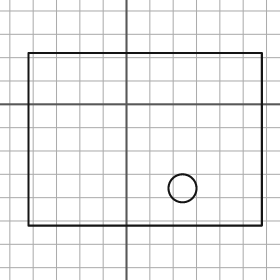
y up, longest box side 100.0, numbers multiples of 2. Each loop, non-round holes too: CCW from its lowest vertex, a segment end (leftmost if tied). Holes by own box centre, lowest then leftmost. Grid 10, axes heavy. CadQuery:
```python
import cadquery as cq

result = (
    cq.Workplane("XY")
    .moveTo(-42.0, -52.0)
    .lineTo(58.0, -52.0)
    .lineTo(58.0, 22.0)
    .lineTo(-42.0, 22.0)
    .close()
    .moveTo(24.0, -36.0)
    .circle(6.0)
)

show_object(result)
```